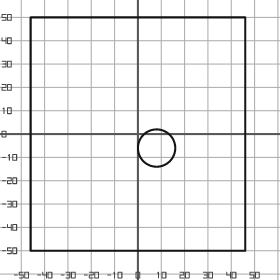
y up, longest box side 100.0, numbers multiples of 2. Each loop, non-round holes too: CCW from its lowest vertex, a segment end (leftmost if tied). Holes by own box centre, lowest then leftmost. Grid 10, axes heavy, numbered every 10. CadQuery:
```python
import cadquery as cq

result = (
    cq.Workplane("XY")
    .moveTo(-46.0, -50.0)
    .lineTo(46.0, -50.0)
    .lineTo(46.0, 50.0)
    .lineTo(-46.0, 50.0)
    .close()
    .moveTo(8.0, -6.0)
    .circle(8.0)
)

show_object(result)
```